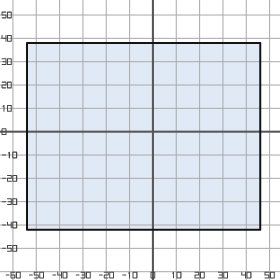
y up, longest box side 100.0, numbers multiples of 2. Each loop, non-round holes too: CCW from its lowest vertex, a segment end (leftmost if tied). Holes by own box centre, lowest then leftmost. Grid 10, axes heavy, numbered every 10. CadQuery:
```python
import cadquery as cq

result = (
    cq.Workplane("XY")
    .moveTo(-54.0, -42.0)
    .lineTo(46.0, -42.0)
    .lineTo(46.0, 38.0)
    .lineTo(-54.0, 38.0)
    .close()
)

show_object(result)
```